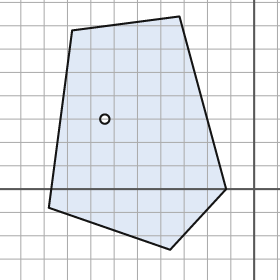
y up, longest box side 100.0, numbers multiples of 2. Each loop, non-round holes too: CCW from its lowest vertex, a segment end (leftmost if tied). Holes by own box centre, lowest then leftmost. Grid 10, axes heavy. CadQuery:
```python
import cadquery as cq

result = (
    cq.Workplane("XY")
    .moveTo(-36.0, -26.0)
    .lineTo(-12.0, 0.0)
    .lineTo(-32.0, 74.0)
    .lineTo(-78.0, 68.0)
    .lineTo(-88.0, -8.0)
    .close()
    .moveTo(-64.0, 30.0)
    .circle(2.0)
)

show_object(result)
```